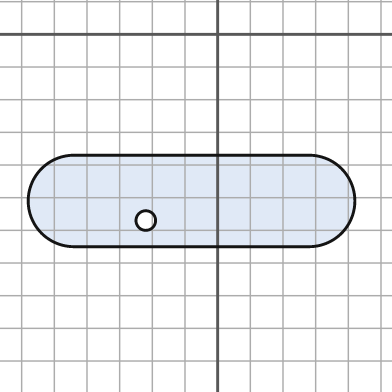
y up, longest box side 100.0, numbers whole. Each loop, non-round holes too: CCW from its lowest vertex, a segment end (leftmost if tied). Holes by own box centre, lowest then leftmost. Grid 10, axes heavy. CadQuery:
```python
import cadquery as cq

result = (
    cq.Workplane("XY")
    .moveTo(-44.0, -65.0)
    .lineTo(28.0, -65.0)
    .threePointArc((42.0, -51.0), (28.0, -37.0))
    .lineTo(-44.0, -37.0)
    .threePointArc((-58.0, -51.0), (-44.0, -65.0))
    .close()
    .moveTo(-22.0, -57.0)
    .circle(3.0)
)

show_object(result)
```